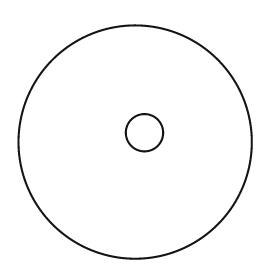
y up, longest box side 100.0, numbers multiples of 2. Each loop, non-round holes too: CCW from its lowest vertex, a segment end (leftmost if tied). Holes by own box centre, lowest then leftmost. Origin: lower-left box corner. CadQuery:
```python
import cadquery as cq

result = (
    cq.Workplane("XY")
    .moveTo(50.0, 50.0)
    .circle(50.0)
    .moveTo(54.0, 54.0)
    .circle(8.0)
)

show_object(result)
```